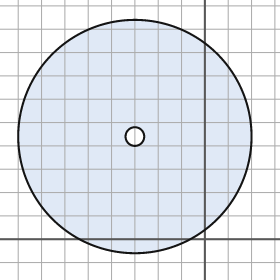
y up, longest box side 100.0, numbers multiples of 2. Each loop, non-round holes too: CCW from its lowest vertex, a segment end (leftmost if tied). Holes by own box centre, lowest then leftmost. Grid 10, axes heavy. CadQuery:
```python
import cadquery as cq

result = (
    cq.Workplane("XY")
    .moveTo(-30.0, 44.0)
    .circle(50.0)
    .moveTo(-30.0, 44.0)
    .circle(4.0)
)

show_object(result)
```